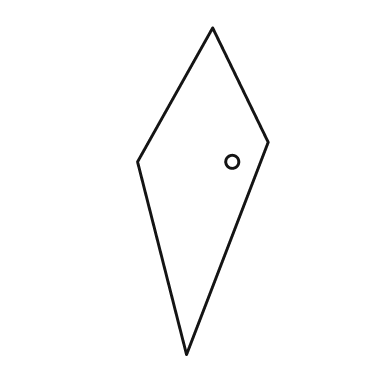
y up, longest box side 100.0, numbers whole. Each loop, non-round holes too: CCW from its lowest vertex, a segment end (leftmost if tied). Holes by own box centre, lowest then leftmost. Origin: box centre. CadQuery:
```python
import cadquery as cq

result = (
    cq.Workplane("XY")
    .moveTo(-5.0, -50.0)
    .lineTo(20.0, 15.0)
    .lineTo(3.0, 50.0)
    .lineTo(-20.0, 9.0)
    .close()
    .moveTo(9.0, 9.0)
    .circle(2.0)
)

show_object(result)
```